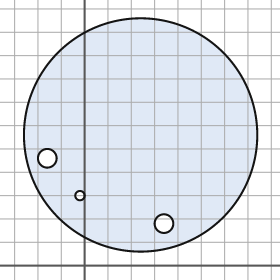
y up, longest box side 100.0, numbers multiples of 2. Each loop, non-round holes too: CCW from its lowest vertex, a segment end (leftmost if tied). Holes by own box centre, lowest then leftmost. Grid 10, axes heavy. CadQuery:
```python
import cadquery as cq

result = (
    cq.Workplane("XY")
    .moveTo(24.0, 56.0)
    .circle(50.0)
    .moveTo(34.0, 18.0)
    .circle(4.0)
    .moveTo(-2.0, 30.0)
    .circle(2.0)
    .moveTo(-16.0, 46.0)
    .circle(4.0)
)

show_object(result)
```